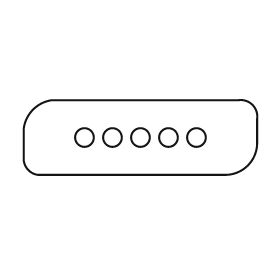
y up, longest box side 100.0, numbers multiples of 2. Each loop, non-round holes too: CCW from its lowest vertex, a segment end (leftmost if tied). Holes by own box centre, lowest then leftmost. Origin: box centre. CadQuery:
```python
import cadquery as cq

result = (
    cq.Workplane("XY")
    .moveTo(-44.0, -16.0)
    .lineTo(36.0, -16.0)
    .threePointArc((46.0, -12.0), (50.0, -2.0))
    .lineTo(50.0, 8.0)
    .threePointArc((48.0, 14.0), (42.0, 16.0))
    .lineTo(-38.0, 16.0)
    .threePointArc((-46.0, 12.0), (-50.0, 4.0))
    .lineTo(-50.0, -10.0)
    .threePointArc((-48.0, -14.0), (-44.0, -16.0))
    .close()
    .moveTo(-24.0, 0.0)
    .circle(4.0)
    .moveTo(-12.0, 0.0)
    .circle(4.0)
    .moveTo(0.0, 0.0)
    .circle(4.0)
    .moveTo(12.0, 0.0)
    .circle(4.0)
    .moveTo(24.0, 0.0)
    .circle(4.0)
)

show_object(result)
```